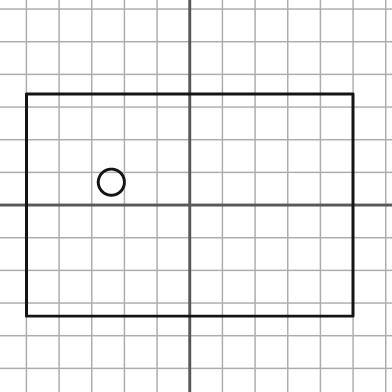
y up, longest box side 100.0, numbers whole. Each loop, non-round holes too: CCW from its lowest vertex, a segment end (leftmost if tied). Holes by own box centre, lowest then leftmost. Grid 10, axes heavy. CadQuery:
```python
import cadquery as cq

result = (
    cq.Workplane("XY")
    .moveTo(-50.0, -34.0)
    .lineTo(50.0, -34.0)
    .lineTo(50.0, 34.0)
    .lineTo(-50.0, 34.0)
    .close()
    .moveTo(-24.0, 7.0)
    .circle(4.0)
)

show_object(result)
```